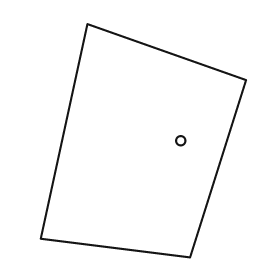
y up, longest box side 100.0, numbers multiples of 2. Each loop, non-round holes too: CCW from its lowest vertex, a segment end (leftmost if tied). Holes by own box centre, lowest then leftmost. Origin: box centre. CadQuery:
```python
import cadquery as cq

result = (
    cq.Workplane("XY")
    .moveTo(20.0, -50.0)
    .lineTo(44.0, 26.0)
    .lineTo(-24.0, 50.0)
    .lineTo(-44.0, -42.0)
    .close()
    .moveTo(16.0, 0.0)
    .circle(2.0)
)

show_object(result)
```